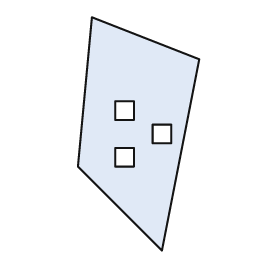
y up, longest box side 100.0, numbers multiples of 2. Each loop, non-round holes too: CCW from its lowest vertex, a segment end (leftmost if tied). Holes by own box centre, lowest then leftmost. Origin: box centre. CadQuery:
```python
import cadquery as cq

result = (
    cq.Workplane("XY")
    .moveTo(10.0, -50.0)
    .lineTo(26.0, 32.0)
    .lineTo(-20.0, 50.0)
    .lineTo(-26.0, -14.0)
    .close()
    .moveTo(-10.0, -14.0)
    .lineTo(-2.0, -14.0)
    .lineTo(-2.0, -6.0)
    .lineTo(-10.0, -6.0)
    .close()
    .moveTo(6.0, -4.0)
    .lineTo(14.0, -4.0)
    .lineTo(14.0, 4.0)
    .lineTo(6.0, 4.0)
    .close()
    .moveTo(-10.0, 6.0)
    .lineTo(-2.0, 6.0)
    .lineTo(-2.0, 14.0)
    .lineTo(-10.0, 14.0)
    .close()
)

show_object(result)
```